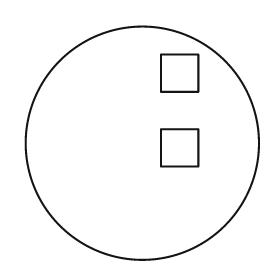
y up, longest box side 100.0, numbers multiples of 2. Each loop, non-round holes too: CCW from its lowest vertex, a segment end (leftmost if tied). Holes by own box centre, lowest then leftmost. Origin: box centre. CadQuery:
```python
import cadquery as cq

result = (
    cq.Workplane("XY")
    .moveTo(0.0, 0.0)
    .circle(50.0)
    .moveTo(8.0, -10.0)
    .lineTo(24.0, -10.0)
    .lineTo(24.0, 6.0)
    .lineTo(8.0, 6.0)
    .close()
    .moveTo(8.0, 22.0)
    .lineTo(24.0, 22.0)
    .lineTo(24.0, 38.0)
    .lineTo(8.0, 38.0)
    .close()
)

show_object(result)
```